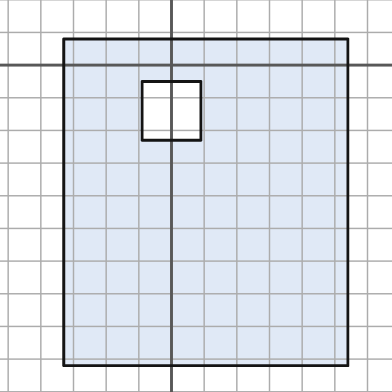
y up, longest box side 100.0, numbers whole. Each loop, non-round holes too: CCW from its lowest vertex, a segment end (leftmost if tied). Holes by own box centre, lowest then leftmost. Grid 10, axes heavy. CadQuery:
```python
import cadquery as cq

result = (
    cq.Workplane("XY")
    .moveTo(-33.0, -92.0)
    .lineTo(54.0, -92.0)
    .lineTo(54.0, 8.0)
    .lineTo(-33.0, 8.0)
    .close()
    .moveTo(-9.0, -23.0)
    .lineTo(9.0, -23.0)
    .lineTo(9.0, -5.0)
    .lineTo(-9.0, -5.0)
    .close()
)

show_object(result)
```